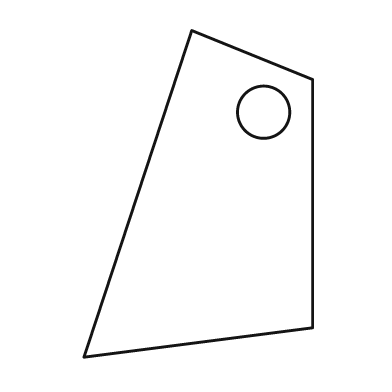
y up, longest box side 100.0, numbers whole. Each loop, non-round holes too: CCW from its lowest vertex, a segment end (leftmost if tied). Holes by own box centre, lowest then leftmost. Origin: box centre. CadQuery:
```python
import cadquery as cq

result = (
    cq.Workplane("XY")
    .moveTo(-35.0, -50.0)
    .lineTo(35.0, -41.0)
    .lineTo(35.0, 35.0)
    .lineTo(-2.0, 50.0)
    .close()
    .moveTo(20.0, 25.0)
    .circle(8.0)
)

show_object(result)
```